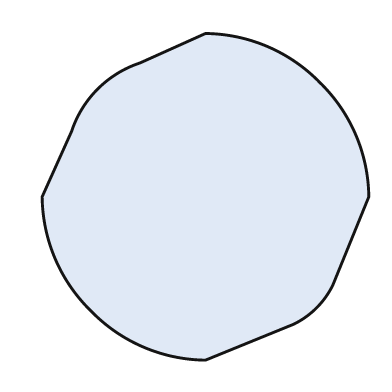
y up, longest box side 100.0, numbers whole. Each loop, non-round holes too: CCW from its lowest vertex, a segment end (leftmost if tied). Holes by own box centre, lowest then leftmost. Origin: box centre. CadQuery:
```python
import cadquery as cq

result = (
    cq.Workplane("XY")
    .moveTo(0.0, -50.0)
    .lineTo(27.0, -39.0)
    .threePointArc((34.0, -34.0), (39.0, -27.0))
    .lineTo(50.0, 0.0)
    .threePointArc((46.0, 19.0), (35.0, 35.0))
    .threePointArc((19.0, 46.0), (0.0, 50.0))
    .lineTo(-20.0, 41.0)
    .threePointArc((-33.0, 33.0), (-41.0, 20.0))
    .lineTo(-50.0, 0.0)
    .threePointArc((-46.0, -19.0), (-35.0, -35.0))
    .threePointArc((-19.0, -46.0), (0.0, -50.0))
    .close()
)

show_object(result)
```